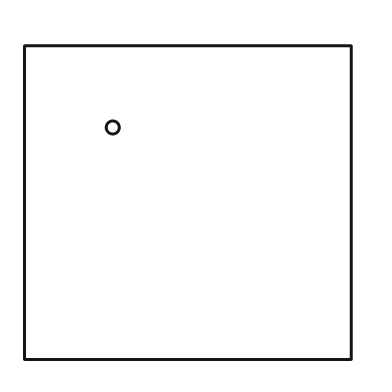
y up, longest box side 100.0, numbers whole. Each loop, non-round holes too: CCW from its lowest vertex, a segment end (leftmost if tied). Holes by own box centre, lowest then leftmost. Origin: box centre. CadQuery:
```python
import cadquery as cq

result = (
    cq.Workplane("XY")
    .moveTo(-50.0, -48.0)
    .lineTo(50.0, -48.0)
    .lineTo(50.0, 48.0)
    .lineTo(-50.0, 48.0)
    .close()
    .moveTo(-23.0, 23.0)
    .circle(2.0)
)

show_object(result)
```